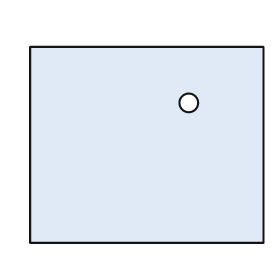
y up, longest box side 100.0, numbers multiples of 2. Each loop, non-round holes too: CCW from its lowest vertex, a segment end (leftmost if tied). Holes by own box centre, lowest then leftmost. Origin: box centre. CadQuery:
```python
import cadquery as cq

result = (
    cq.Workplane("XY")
    .moveTo(-50.0, -42.0)
    .lineTo(50.0, -42.0)
    .lineTo(50.0, 42.0)
    .lineTo(-50.0, 42.0)
    .close()
    .moveTo(18.0, 18.0)
    .circle(4.0)
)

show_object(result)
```